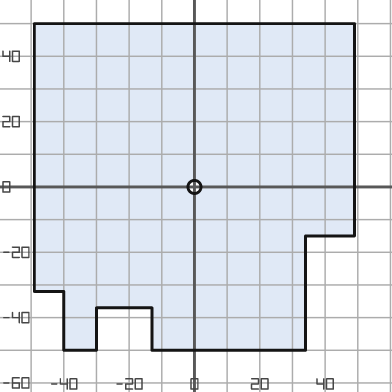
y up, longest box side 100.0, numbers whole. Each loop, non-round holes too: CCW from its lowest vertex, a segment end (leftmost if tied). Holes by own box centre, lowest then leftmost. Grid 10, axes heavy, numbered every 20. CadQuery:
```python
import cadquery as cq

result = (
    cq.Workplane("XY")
    .moveTo(-40.0, -50.0)
    .lineTo(-30.0, -50.0)
    .lineTo(-30.0, -37.0)
    .lineTo(-13.0, -37.0)
    .lineTo(-13.0, -50.0)
    .lineTo(34.0, -50.0)
    .lineTo(34.0, -15.0)
    .lineTo(49.0, -15.0)
    .lineTo(49.0, 50.0)
    .lineTo(-49.0, 50.0)
    .lineTo(-49.0, -32.0)
    .lineTo(-40.0, -32.0)
    .close()
    .moveTo(0.0, 0.0)
    .circle(2.0)
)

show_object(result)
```